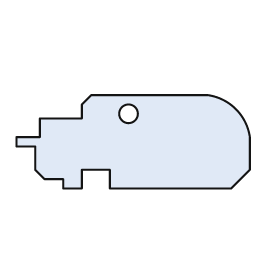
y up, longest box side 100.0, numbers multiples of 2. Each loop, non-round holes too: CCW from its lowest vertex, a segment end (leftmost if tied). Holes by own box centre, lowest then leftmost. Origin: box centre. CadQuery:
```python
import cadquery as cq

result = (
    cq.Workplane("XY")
    .moveTo(-30.0, -20.0)
    .lineTo(-22.0, -20.0)
    .lineTo(-22.0, -12.0)
    .lineTo(-10.0, -12.0)
    .lineTo(-10.0, -20.0)
    .lineTo(42.0, -20.0)
    .lineTo(50.0, -12.0)
    .lineTo(50.0, 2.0)
    .threePointArc((44.0, 14.0), (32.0, 20.0))
    .lineTo(-18.0, 20.0)
    .lineTo(-22.0, 16.0)
    .lineTo(-22.0, 10.0)
    .lineTo(-40.0, 10.0)
    .lineTo(-40.0, 2.0)
    .lineTo(-50.0, 2.0)
    .lineTo(-50.0, -2.0)
    .lineTo(-42.0, -2.0)
    .lineTo(-42.0, -12.0)
    .lineTo(-38.0, -16.0)
    .lineTo(-30.0, -16.0)
    .close()
    .moveTo(-2.0, 12.0)
    .circle(4.0)
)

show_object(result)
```